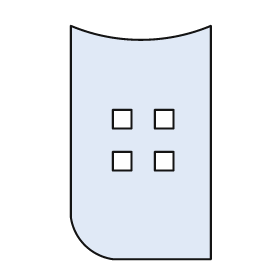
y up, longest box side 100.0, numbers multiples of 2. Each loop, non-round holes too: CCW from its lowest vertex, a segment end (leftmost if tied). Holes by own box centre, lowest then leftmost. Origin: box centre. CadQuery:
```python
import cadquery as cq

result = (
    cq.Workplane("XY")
    .moveTo(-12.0, -50.0)
    .lineTo(30.0, -50.0)
    .lineTo(30.0, 50.0)
    .threePointArc((0.0, 44.0), (-30.0, 50.0))
    .lineTo(-30.0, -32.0)
    .threePointArc((-24.0, -44.0), (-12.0, -50.0))
    .close()
    .moveTo(-12.0, -12.0)
    .lineTo(-4.0, -12.0)
    .lineTo(-4.0, -4.0)
    .lineTo(-12.0, -4.0)
    .close()
    .moveTo(6.0, -12.0)
    .lineTo(14.0, -12.0)
    .lineTo(14.0, -4.0)
    .lineTo(6.0, -4.0)
    .close()
    .moveTo(-12.0, 6.0)
    .lineTo(-4.0, 6.0)
    .lineTo(-4.0, 14.0)
    .lineTo(-12.0, 14.0)
    .close()
    .moveTo(6.0, 6.0)
    .lineTo(14.0, 6.0)
    .lineTo(14.0, 14.0)
    .lineTo(6.0, 14.0)
    .close()
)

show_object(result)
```